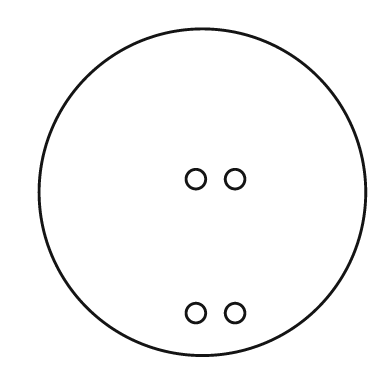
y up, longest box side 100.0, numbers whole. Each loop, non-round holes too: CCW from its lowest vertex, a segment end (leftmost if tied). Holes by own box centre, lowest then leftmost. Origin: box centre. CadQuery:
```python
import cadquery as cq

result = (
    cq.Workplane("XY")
    .moveTo(0.0, 0.0)
    .circle(50.0)
    .moveTo(-2.0, -37.0)
    .circle(3.0)
    .moveTo(10.0, -37.0)
    .circle(3.0)
    .moveTo(-2.0, 4.0)
    .circle(3.0)
    .moveTo(10.0, 4.0)
    .circle(3.0)
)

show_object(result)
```